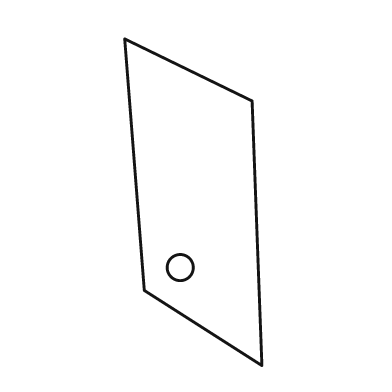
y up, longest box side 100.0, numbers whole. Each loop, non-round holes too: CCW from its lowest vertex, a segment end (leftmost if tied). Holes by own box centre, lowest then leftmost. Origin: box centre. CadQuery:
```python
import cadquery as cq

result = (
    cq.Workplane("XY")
    .moveTo(21.0, -50.0)
    .lineTo(18.0, 31.0)
    .lineTo(-21.0, 50.0)
    .lineTo(-15.0, -27.0)
    .close()
    .moveTo(-4.0, -20.0)
    .circle(4.0)
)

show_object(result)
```